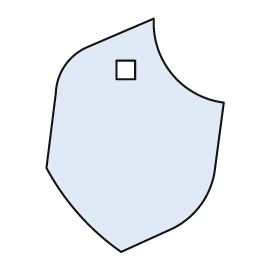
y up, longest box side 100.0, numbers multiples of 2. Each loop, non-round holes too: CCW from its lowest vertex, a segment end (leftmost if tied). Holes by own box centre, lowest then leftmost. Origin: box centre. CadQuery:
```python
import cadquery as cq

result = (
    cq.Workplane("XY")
    .moveTo(-6.0, -50.0)
    .lineTo(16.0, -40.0)
    .threePointArc((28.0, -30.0), (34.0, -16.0))
    .lineTo(38.0, 14.0)
    .threePointArc((16.0, 26.0), (8.0, 50.0))
    .lineTo(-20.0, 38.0)
    .threePointArc((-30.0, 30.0), (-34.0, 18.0))
    .lineTo(-38.0, -14.0)
    .threePointArc((-24.0, -34.0), (-6.0, -50.0))
    .close()
    .moveTo(-8.0, 24.0)
    .lineTo(0.0, 24.0)
    .lineTo(0.0, 32.0)
    .lineTo(-8.0, 32.0)
    .close()
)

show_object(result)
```